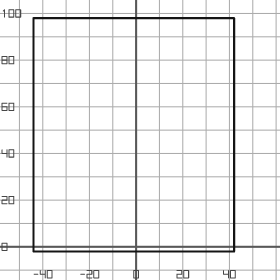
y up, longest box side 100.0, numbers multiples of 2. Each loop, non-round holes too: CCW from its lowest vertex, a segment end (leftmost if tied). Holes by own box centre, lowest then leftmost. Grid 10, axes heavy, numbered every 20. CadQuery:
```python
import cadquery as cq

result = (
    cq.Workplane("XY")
    .moveTo(-44.0, -2.0)
    .lineTo(42.0, -2.0)
    .lineTo(42.0, 98.0)
    .lineTo(-44.0, 98.0)
    .close()
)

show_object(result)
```